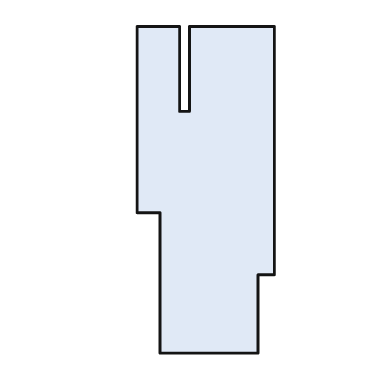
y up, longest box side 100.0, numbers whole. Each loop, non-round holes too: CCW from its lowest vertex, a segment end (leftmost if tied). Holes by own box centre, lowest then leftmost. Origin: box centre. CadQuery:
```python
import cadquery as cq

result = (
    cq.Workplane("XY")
    .moveTo(-14.0, -50.0)
    .lineTo(16.0, -50.0)
    .lineTo(16.0, -26.0)
    .lineTo(21.0, -26.0)
    .lineTo(21.0, 50.0)
    .lineTo(-5.0, 50.0)
    .lineTo(-5.0, 24.0)
    .lineTo(-8.0, 24.0)
    .lineTo(-8.0, 50.0)
    .lineTo(-21.0, 50.0)
    .lineTo(-21.0, -7.0)
    .lineTo(-14.0, -7.0)
    .close()
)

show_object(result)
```